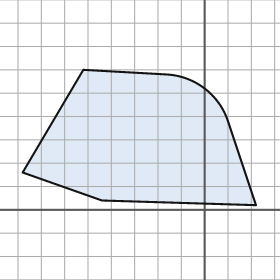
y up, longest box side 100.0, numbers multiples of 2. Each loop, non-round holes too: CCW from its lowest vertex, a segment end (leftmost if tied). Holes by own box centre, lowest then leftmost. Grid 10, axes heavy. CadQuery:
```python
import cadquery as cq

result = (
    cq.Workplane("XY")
    .moveTo(22.0, 2.0)
    .lineTo(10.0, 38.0)
    .threePointArc((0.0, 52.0), (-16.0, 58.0))
    .lineTo(-52.0, 60.0)
    .lineTo(-78.0, 16.0)
    .lineTo(-44.0, 4.0)
    .close()
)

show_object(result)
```